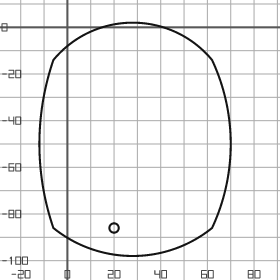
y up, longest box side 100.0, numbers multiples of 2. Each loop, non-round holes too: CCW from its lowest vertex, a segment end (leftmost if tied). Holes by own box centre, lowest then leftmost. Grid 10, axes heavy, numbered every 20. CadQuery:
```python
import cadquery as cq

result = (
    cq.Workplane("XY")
    .moveTo(-6.0, -86.0)
    .threePointArc((28.0, -98.0), (62.0, -86.0))
    .threePointArc((70.0, -50.0), (62.0, -14.0))
    .threePointArc((28.0, 2.0), (-6.0, -14.0))
    .threePointArc((-12.0, -50.0), (-6.0, -86.0))
    .close()
    .moveTo(20.0, -86.0)
    .circle(2.0)
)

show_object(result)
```